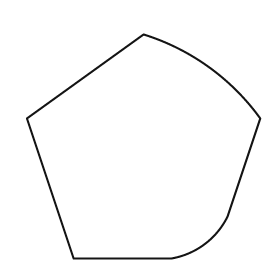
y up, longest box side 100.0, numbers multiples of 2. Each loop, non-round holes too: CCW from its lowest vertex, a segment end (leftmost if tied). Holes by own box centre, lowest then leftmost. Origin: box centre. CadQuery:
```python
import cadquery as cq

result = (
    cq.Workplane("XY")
    .moveTo(-30.0, -48.0)
    .lineTo(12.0, -48.0)
    .threePointArc((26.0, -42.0), (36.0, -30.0))
    .lineTo(50.0, 12.0)
    .threePointArc((28.0, 34.0), (0.0, 48.0))
    .lineTo(-50.0, 12.0)
    .close()
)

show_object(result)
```